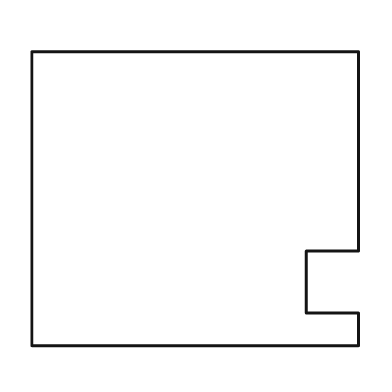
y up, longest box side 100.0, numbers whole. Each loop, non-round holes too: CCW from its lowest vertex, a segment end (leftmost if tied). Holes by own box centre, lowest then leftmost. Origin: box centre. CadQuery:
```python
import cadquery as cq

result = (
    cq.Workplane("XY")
    .moveTo(-50.0, -45.0)
    .lineTo(50.0, -45.0)
    .lineTo(50.0, -35.0)
    .lineTo(34.0, -35.0)
    .lineTo(34.0, -16.0)
    .lineTo(50.0, -16.0)
    .lineTo(50.0, 45.0)
    .lineTo(-50.0, 45.0)
    .close()
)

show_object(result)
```